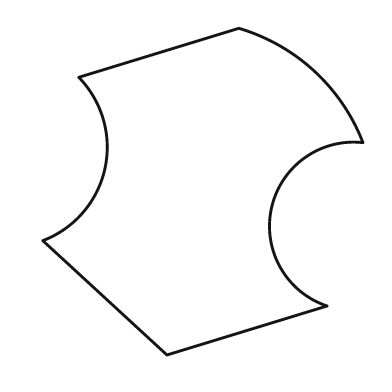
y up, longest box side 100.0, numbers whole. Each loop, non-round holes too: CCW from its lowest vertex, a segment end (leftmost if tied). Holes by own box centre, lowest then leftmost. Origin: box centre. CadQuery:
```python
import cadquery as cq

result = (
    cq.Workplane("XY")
    .moveTo(-11.0, -50.0)
    .lineTo(38.0, -35.0)
    .threePointArc((21.0, -5.0), (49.0, 15.0))
    .threePointArc((34.0, 37.0), (11.0, 50.0))
    .lineTo(-38.0, 35.0)
    .threePointArc((-30.0, 7.0), (-49.0, -15.0))
    .close()
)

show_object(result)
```